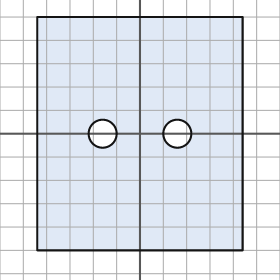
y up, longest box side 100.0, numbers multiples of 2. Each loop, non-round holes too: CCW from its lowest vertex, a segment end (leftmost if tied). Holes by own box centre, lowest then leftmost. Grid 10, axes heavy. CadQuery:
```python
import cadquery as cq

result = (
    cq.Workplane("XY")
    .moveTo(-44.0, -50.0)
    .lineTo(44.0, -50.0)
    .lineTo(44.0, 50.0)
    .lineTo(-44.0, 50.0)
    .close()
    .moveTo(-16.0, 0.0)
    .circle(6.0)
    .moveTo(16.0, 0.0)
    .circle(6.0)
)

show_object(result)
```